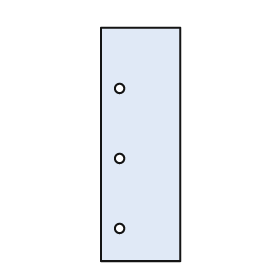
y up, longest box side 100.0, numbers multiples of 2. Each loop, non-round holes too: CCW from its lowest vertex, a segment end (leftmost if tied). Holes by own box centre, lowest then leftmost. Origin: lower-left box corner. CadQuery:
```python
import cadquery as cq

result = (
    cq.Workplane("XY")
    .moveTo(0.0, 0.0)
    .lineTo(34.0, 0.0)
    .lineTo(34.0, 100.0)
    .lineTo(0.0, 100.0)
    .close()
    .moveTo(8.0, 14.0)
    .circle(2.0)
    .moveTo(8.0, 44.0)
    .circle(2.0)
    .moveTo(8.0, 74.0)
    .circle(2.0)
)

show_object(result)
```